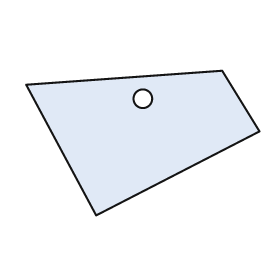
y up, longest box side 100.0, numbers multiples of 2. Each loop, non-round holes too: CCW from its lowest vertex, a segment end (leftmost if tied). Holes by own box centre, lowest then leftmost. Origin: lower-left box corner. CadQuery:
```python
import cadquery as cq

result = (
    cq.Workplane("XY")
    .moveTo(30.0, 0.0)
    .lineTo(100.0, 36.0)
    .lineTo(84.0, 62.0)
    .lineTo(0.0, 56.0)
    .close()
    .moveTo(50.0, 50.0)
    .circle(4.0)
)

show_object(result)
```